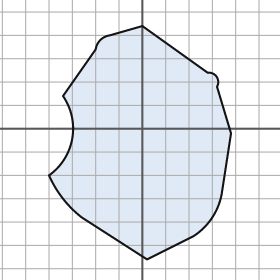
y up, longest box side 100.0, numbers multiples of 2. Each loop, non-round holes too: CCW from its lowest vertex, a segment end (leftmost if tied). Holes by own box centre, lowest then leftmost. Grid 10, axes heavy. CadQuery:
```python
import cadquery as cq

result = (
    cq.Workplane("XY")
    .moveTo(2.0, -56.0)
    .lineTo(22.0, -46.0)
    .threePointArc((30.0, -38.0), (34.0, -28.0))
    .lineTo(38.0, -2.0)
    .lineTo(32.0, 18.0)
    .threePointArc((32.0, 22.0), (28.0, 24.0))
    .lineTo(0.0, 44.0)
    .lineTo(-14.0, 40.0)
    .threePointArc((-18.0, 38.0), (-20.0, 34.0))
    .lineTo(-34.0, 14.0)
    .threePointArc((-30.0, -4.0), (-40.0, -20.0))
    .threePointArc((-34.0, -30.0), (-26.0, -38.0))
    .close()
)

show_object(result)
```